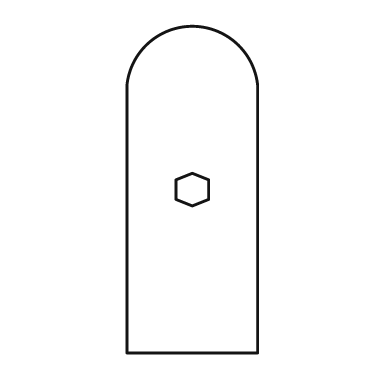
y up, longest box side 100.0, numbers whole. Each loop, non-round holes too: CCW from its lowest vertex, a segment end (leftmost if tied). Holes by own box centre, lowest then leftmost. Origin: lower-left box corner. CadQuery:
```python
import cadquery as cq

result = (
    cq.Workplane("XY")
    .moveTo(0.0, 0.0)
    .lineTo(40.0, 0.0)
    .lineTo(40.0, 82.0)
    .threePointArc((20.0, 100.0), (0.0, 82.0))
    .close()
    .moveTo(20.0, 45.0)
    .lineTo(25.0, 47.0)
    .lineTo(25.0, 53.0)
    .lineTo(20.0, 55.0)
    .lineTo(15.0, 53.0)
    .lineTo(15.0, 47.0)
    .close()
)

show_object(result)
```